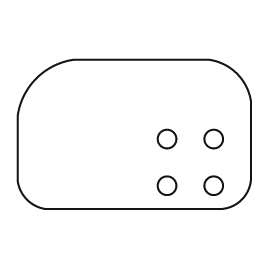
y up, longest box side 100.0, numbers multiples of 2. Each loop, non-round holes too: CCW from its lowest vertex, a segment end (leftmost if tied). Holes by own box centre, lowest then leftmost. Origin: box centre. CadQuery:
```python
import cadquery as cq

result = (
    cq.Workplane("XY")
    .moveTo(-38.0, -32.0)
    .lineTo(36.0, -32.0)
    .threePointArc((46.0, -28.0), (50.0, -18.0))
    .lineTo(50.0, 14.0)
    .threePointArc((44.0, 26.0), (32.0, 32.0))
    .lineTo(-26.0, 32.0)
    .threePointArc((-42.0, 24.0), (-50.0, 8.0))
    .lineTo(-50.0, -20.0)
    .threePointArc((-46.0, -28.0), (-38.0, -32.0))
    .close()
    .moveTo(14.0, -22.0)
    .circle(4.0)
    .moveTo(34.0, -22.0)
    .circle(4.0)
    .moveTo(14.0, -2.0)
    .circle(4.0)
    .moveTo(34.0, -2.0)
    .circle(4.0)
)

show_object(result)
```